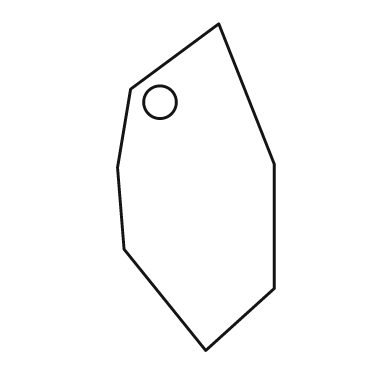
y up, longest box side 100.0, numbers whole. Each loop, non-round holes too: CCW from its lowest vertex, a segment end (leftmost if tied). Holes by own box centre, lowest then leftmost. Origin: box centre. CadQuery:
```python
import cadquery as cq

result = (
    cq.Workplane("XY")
    .moveTo(3.0, -50.0)
    .lineTo(24.0, -31.0)
    .lineTo(24.0, 7.0)
    .lineTo(7.0, 50.0)
    .lineTo(-20.0, 30.0)
    .lineTo(-24.0, 6.0)
    .lineTo(-22.0, -19.0)
    .close()
    .moveTo(-11.0, 26.0)
    .circle(5.0)
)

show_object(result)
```